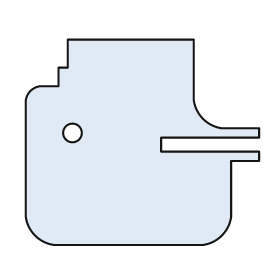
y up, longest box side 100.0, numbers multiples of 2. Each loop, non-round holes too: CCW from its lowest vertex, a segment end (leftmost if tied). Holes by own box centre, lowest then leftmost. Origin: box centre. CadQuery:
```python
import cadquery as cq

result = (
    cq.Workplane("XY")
    .moveTo(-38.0, -44.0)
    .lineTo(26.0, -44.0)
    .threePointArc((34.0, -40.0), (38.0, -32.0))
    .lineTo(38.0, -8.0)
    .lineTo(50.0, -8.0)
    .lineTo(50.0, -4.0)
    .lineTo(8.0, -4.0)
    .lineTo(8.0, 2.0)
    .lineTo(50.0, 2.0)
    .lineTo(50.0, 6.0)
    .lineTo(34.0, 6.0)
    .threePointArc((26.0, 10.0), (22.0, 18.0))
    .lineTo(22.0, 44.0)
    .lineTo(-32.0, 44.0)
    .lineTo(-32.0, 32.0)
    .lineTo(-36.0, 32.0)
    .lineTo(-36.0, 24.0)
    .lineTo(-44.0, 24.0)
    .threePointArc((-48.0, 22.0), (-50.0, 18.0))
    .lineTo(-50.0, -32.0)
    .threePointArc((-46.0, -40.0), (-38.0, -44.0))
    .close()
    .moveTo(-30.0, 4.0)
    .circle(4.0)
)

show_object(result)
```